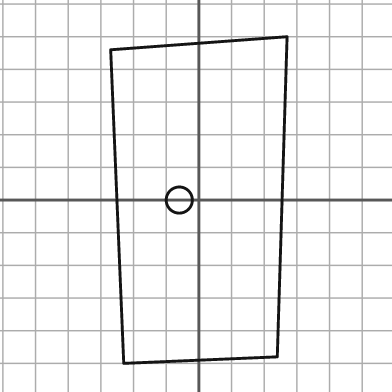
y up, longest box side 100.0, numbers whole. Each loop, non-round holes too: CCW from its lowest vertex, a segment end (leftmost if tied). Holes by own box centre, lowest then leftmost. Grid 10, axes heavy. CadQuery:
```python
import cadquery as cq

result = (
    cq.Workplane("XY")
    .moveTo(-23.0, -50.0)
    .lineTo(24.0, -48.0)
    .lineTo(27.0, 50.0)
    .lineTo(-27.0, 46.0)
    .close()
    .moveTo(-6.0, 0.0)
    .circle(4.0)
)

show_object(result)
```